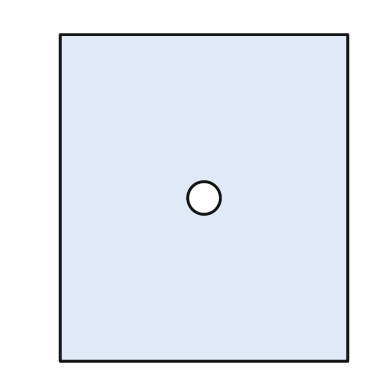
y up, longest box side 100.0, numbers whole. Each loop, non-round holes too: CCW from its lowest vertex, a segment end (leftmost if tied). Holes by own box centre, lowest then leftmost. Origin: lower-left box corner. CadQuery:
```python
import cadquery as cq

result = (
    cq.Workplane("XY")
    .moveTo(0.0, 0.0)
    .lineTo(88.0, 0.0)
    .lineTo(88.0, 100.0)
    .lineTo(0.0, 100.0)
    .close()
    .moveTo(44.0, 50.0)
    .circle(5.0)
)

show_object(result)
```